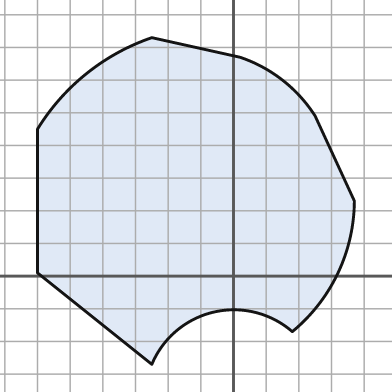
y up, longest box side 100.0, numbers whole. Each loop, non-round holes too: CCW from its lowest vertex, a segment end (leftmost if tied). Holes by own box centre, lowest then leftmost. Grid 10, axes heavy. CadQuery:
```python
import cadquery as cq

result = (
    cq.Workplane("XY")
    .moveTo(-25.0, -27.0)
    .threePointArc((-6.0, -11.0), (18.0, -17.0))
    .threePointArc((32.0, 1.0), (37.0, 23.0))
    .lineTo(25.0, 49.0)
    .threePointArc((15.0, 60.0), (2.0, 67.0))
    .lineTo(-25.0, 73.0)
    .threePointArc((-45.0, 62.0), (-60.0, 45.0))
    .lineTo(-60.0, 1.0)
    .close()
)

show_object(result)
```